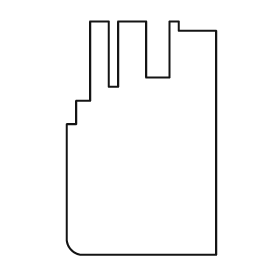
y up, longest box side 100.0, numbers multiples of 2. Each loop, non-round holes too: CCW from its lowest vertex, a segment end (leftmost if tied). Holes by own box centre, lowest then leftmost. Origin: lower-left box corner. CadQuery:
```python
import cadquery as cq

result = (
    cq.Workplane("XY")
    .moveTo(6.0, 0.0)
    .lineTo(64.0, 0.0)
    .lineTo(64.0, 96.0)
    .lineTo(48.0, 96.0)
    .lineTo(48.0, 100.0)
    .lineTo(44.0, 100.0)
    .lineTo(44.0, 76.0)
    .lineTo(34.0, 76.0)
    .lineTo(34.0, 100.0)
    .lineTo(22.0, 100.0)
    .lineTo(22.0, 72.0)
    .lineTo(18.0, 72.0)
    .lineTo(18.0, 100.0)
    .lineTo(10.0, 100.0)
    .lineTo(10.0, 66.0)
    .lineTo(4.0, 66.0)
    .lineTo(4.0, 56.0)
    .lineTo(0.0, 56.0)
    .lineTo(0.0, 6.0)
    .threePointArc((2.0, 2.0), (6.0, 0.0))
    .close()
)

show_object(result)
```